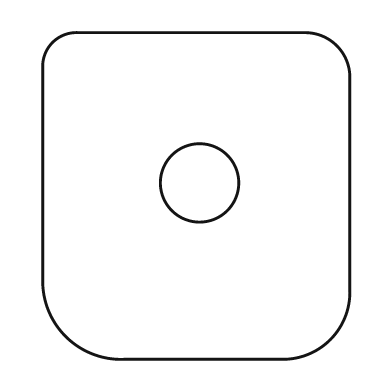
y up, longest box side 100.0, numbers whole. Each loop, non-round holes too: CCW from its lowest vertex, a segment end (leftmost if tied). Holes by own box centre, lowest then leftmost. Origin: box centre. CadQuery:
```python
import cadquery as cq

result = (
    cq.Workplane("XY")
    .moveTo(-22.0, -50.0)
    .lineTo(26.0, -50.0)
    .threePointArc((41.0, -44.0), (47.0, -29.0))
    .lineTo(47.0, 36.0)
    .threePointArc((43.0, 46.0), (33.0, 50.0))
    .lineTo(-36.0, 50.0)
    .threePointArc((-44.0, 47.0), (-47.0, 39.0))
    .lineTo(-47.0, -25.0)
    .threePointArc((-40.0, -43.0), (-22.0, -50.0))
    .close()
    .moveTo(1.0, 4.0)
    .circle(12.0)
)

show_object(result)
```